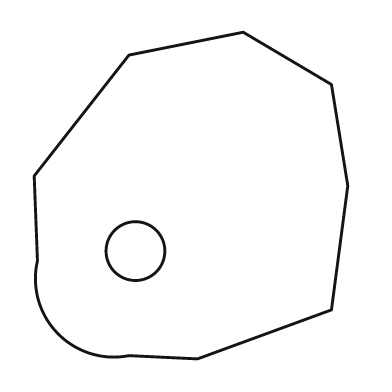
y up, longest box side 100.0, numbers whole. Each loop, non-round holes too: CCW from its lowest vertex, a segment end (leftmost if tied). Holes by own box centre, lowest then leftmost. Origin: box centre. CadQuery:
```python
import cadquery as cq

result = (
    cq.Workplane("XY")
    .moveTo(2.0, -50.0)
    .lineTo(43.0, -35.0)
    .lineTo(48.0, 3.0)
    .lineTo(43.0, 34.0)
    .lineTo(16.0, 50.0)
    .lineTo(-19.0, 43.0)
    .lineTo(-48.0, 6.0)
    .lineTo(-47.0, -20.0)
    .threePointArc((-41.0, -42.0), (-19.0, -49.0))
    .close()
    .moveTo(-17.0, -17.0)
    .circle(9.0)
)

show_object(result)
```